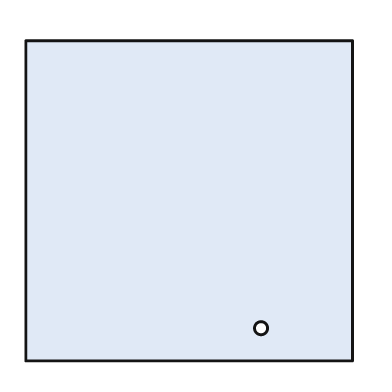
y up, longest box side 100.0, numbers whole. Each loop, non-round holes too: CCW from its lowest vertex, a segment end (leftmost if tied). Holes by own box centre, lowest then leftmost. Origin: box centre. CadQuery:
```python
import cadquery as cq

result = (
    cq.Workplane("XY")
    .moveTo(-50.0, -49.0)
    .lineTo(50.0, -49.0)
    .lineTo(50.0, 49.0)
    .lineTo(-50.0, 49.0)
    .close()
    .moveTo(22.0, -39.0)
    .circle(2.0)
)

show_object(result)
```